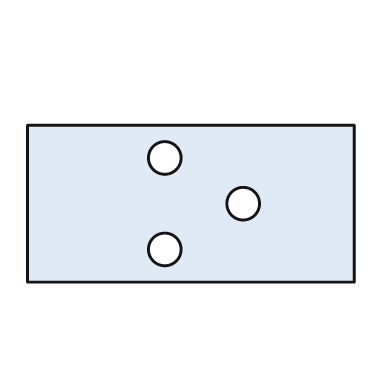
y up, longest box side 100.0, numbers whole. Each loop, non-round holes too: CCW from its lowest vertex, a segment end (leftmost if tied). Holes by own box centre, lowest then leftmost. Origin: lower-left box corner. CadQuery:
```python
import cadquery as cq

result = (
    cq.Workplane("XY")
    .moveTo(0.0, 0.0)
    .lineTo(100.0, 0.0)
    .lineTo(100.0, 48.0)
    .lineTo(0.0, 48.0)
    .close()
    .moveTo(42.0, 10.0)
    .circle(5.0)
    .moveTo(66.0, 24.0)
    .circle(5.0)
    .moveTo(42.0, 38.0)
    .circle(5.0)
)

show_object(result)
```